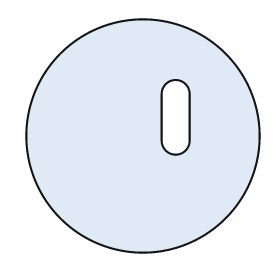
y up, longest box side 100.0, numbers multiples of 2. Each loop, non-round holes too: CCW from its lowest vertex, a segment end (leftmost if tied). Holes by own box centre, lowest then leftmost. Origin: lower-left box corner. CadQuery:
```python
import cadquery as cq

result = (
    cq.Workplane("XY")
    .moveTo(50.0, 50.0)
    .circle(50.0)
    .moveTo(58.0, 48.0)
    .threePointArc((64.0, 42.0), (70.0, 48.0))
    .lineTo(70.0, 68.0)
    .threePointArc((64.0, 74.0), (58.0, 68.0))
    .close()
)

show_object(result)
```